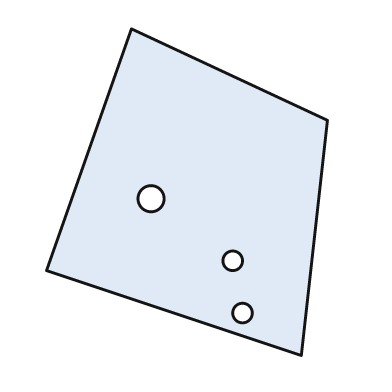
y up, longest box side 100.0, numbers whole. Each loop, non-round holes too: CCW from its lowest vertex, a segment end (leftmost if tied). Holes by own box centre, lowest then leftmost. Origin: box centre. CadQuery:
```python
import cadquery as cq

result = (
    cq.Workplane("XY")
    .moveTo(35.0, -50.0)
    .lineTo(43.0, 22.0)
    .lineTo(-17.0, 50.0)
    .lineTo(-43.0, -24.0)
    .close()
    .moveTo(17.0, -37.0)
    .circle(3.0)
    .moveTo(14.0, -21.0)
    .circle(3.0)
    .moveTo(-11.0, -2.0)
    .circle(4.0)
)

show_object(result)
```